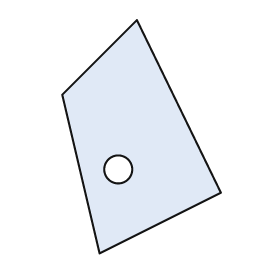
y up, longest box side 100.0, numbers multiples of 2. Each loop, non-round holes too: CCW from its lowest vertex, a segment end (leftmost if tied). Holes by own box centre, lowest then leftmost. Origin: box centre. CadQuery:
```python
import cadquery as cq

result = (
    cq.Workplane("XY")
    .moveTo(-18.0, -50.0)
    .lineTo(34.0, -24.0)
    .lineTo(-2.0, 50.0)
    .lineTo(-34.0, 18.0)
    .close()
    .moveTo(-10.0, -14.0)
    .circle(6.0)
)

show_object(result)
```